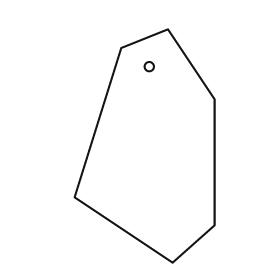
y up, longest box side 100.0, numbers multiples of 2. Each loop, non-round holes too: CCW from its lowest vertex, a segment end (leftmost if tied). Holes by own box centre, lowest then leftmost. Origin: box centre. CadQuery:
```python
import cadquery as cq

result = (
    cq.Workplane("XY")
    .moveTo(12.0, -50.0)
    .lineTo(30.0, -34.0)
    .lineTo(30.0, 20.0)
    .lineTo(10.0, 50.0)
    .lineTo(-10.0, 42.0)
    .lineTo(-30.0, -22.0)
    .close()
    .moveTo(2.0, 34.0)
    .circle(2.0)
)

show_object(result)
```